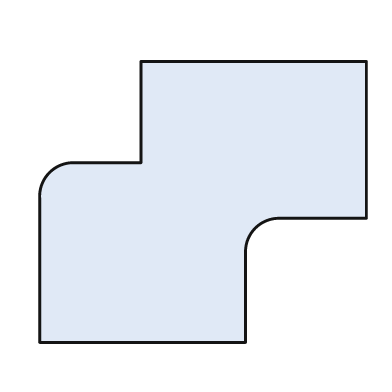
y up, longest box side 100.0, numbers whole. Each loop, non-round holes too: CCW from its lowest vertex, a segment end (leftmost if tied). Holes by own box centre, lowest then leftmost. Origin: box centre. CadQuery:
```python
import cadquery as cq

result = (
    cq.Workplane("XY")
    .moveTo(-50.0, -43.0)
    .lineTo(13.0, -43.0)
    .lineTo(13.0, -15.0)
    .threePointArc((16.0, -8.0), (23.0, -5.0))
    .lineTo(50.0, -5.0)
    .lineTo(50.0, 43.0)
    .lineTo(-19.0, 43.0)
    .lineTo(-19.0, 12.0)
    .lineTo(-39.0, 12.0)
    .threePointArc((-47.0, 9.0), (-50.0, 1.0))
    .close()
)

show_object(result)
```